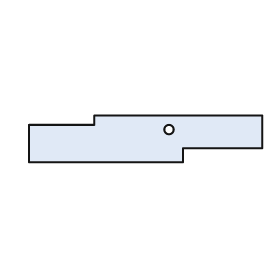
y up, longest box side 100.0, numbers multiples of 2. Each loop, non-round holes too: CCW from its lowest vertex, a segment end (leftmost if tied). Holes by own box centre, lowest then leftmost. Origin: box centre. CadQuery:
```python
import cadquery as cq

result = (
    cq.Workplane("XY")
    .moveTo(-50.0, -10.0)
    .lineTo(16.0, -10.0)
    .lineTo(16.0, -4.0)
    .lineTo(50.0, -4.0)
    .lineTo(50.0, 10.0)
    .lineTo(-22.0, 10.0)
    .lineTo(-22.0, 6.0)
    .lineTo(-50.0, 6.0)
    .close()
    .moveTo(10.0, 4.0)
    .circle(2.0)
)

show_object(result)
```